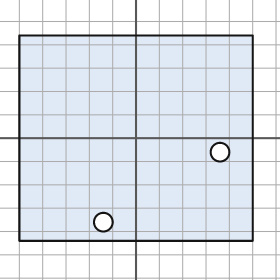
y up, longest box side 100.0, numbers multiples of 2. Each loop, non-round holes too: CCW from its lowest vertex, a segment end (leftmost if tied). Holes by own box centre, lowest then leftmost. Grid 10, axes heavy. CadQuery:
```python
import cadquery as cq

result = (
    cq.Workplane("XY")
    .moveTo(-50.0, -44.0)
    .lineTo(50.0, -44.0)
    .lineTo(50.0, 44.0)
    .lineTo(-50.0, 44.0)
    .close()
    .moveTo(-14.0, -36.0)
    .circle(4.0)
    .moveTo(36.0, -6.0)
    .circle(4.0)
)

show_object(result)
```